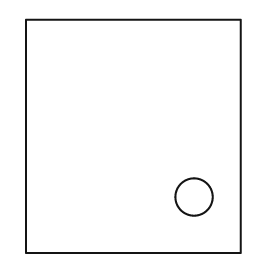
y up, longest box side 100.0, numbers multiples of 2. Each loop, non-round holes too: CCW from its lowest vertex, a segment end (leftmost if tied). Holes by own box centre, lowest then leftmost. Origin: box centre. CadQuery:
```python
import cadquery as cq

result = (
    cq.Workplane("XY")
    .moveTo(-46.0, -50.0)
    .lineTo(46.0, -50.0)
    .lineTo(46.0, 50.0)
    .lineTo(-46.0, 50.0)
    .close()
    .moveTo(26.0, -26.0)
    .circle(8.0)
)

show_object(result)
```